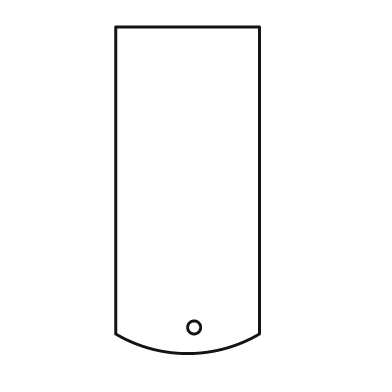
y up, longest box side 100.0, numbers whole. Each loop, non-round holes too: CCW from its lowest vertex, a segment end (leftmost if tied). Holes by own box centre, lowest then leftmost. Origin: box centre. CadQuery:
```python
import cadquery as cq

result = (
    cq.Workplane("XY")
    .moveTo(-22.0, -44.0)
    .threePointArc((0.0, -50.0), (22.0, -44.0))
    .lineTo(22.0, 50.0)
    .lineTo(-22.0, 50.0)
    .close()
    .moveTo(2.0, -42.0)
    .circle(2.0)
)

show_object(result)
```